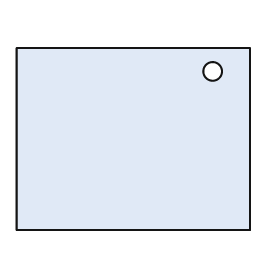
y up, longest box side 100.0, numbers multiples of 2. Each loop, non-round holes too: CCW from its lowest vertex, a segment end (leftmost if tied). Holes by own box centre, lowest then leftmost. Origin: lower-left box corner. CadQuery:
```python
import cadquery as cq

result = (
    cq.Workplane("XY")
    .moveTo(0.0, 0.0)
    .lineTo(100.0, 0.0)
    .lineTo(100.0, 78.0)
    .lineTo(0.0, 78.0)
    .close()
    .moveTo(84.0, 68.0)
    .circle(4.0)
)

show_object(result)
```